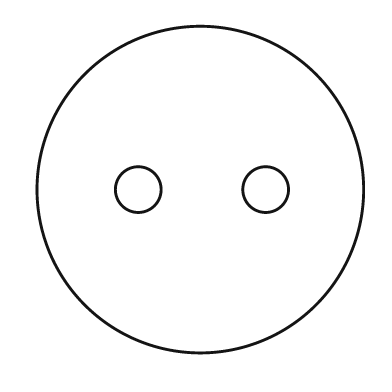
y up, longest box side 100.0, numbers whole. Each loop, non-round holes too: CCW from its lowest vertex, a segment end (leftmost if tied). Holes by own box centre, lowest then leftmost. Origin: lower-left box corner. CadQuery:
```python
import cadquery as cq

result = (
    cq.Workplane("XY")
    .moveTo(50.0, 50.0)
    .circle(50.0)
    .moveTo(31.0, 50.0)
    .circle(7.0)
    .moveTo(70.0, 50.0)
    .circle(7.0)
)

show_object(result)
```